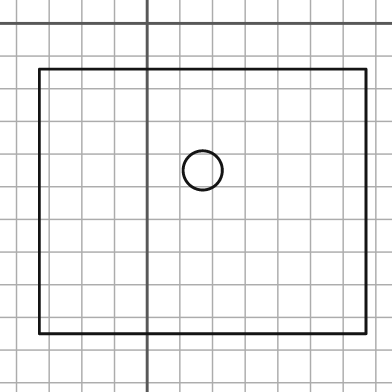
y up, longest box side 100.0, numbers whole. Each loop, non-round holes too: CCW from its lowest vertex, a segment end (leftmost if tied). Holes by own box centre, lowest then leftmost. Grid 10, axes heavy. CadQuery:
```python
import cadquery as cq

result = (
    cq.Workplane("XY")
    .moveTo(-33.0, -95.0)
    .lineTo(67.0, -95.0)
    .lineTo(67.0, -14.0)
    .lineTo(-33.0, -14.0)
    .close()
    .moveTo(17.0, -45.0)
    .circle(6.0)
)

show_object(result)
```